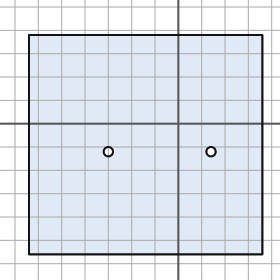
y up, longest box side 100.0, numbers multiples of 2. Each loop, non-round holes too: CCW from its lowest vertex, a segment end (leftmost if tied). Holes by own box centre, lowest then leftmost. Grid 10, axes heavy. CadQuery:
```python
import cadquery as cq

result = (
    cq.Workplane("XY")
    .moveTo(-64.0, -56.0)
    .lineTo(36.0, -56.0)
    .lineTo(36.0, 38.0)
    .lineTo(-64.0, 38.0)
    .close()
    .moveTo(-30.0, -12.0)
    .circle(2.0)
    .moveTo(14.0, -12.0)
    .circle(2.0)
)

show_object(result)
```